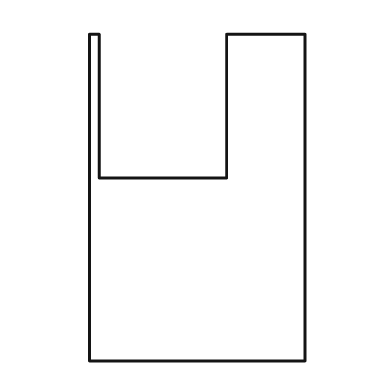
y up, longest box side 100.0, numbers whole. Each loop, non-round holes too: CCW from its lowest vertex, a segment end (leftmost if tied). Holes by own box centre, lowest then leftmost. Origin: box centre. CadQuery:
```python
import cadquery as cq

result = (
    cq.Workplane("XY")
    .moveTo(-33.0, -50.0)
    .lineTo(33.0, -50.0)
    .lineTo(33.0, 50.0)
    .lineTo(9.0, 50.0)
    .lineTo(9.0, 6.0)
    .lineTo(-30.0, 6.0)
    .lineTo(-30.0, 50.0)
    .lineTo(-33.0, 50.0)
    .close()
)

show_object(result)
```